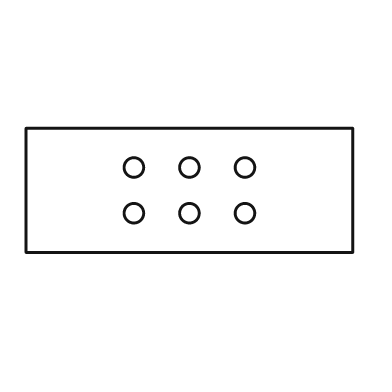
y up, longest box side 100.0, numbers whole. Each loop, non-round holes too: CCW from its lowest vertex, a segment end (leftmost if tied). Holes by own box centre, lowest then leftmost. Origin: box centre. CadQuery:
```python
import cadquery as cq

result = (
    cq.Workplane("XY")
    .moveTo(-50.0, -19.0)
    .lineTo(50.0, -19.0)
    .lineTo(50.0, 19.0)
    .lineTo(-50.0, 19.0)
    .close()
    .moveTo(-17.0, -7.0)
    .circle(3.0)
    .moveTo(0.0, -7.0)
    .circle(3.0)
    .moveTo(17.0, -7.0)
    .circle(3.0)
    .moveTo(-17.0, 7.0)
    .circle(3.0)
    .moveTo(0.0, 7.0)
    .circle(3.0)
    .moveTo(17.0, 7.0)
    .circle(3.0)
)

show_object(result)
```